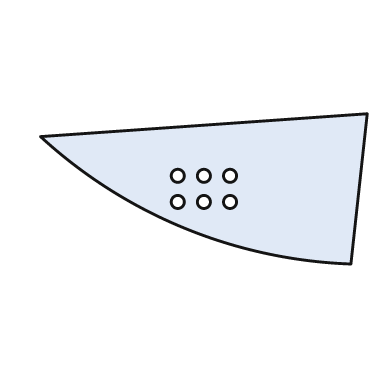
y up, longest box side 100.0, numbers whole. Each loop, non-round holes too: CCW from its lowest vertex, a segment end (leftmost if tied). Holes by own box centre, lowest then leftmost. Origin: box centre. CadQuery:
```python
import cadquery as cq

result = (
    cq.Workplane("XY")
    .moveTo(45.0, -23.0)
    .lineTo(50.0, 23.0)
    .lineTo(-50.0, 16.0)
    .threePointArc((-6.0, -12.0), (45.0, -23.0))
    .close()
    .moveTo(-8.0, -4.0)
    .circle(2.0)
    .moveTo(0.0, -4.0)
    .circle(2.0)
    .moveTo(8.0, -4.0)
    .circle(2.0)
    .moveTo(-8.0, 4.0)
    .circle(2.0)
    .moveTo(0.0, 4.0)
    .circle(2.0)
    .moveTo(8.0, 4.0)
    .circle(2.0)
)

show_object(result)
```